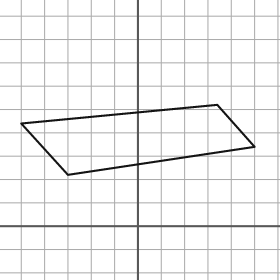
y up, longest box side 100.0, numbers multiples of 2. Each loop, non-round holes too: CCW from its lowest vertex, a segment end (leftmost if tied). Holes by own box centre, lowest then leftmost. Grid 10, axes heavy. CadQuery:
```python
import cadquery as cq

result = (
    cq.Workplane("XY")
    .moveTo(-30.0, 22.0)
    .lineTo(50.0, 34.0)
    .lineTo(34.0, 52.0)
    .lineTo(-50.0, 44.0)
    .close()
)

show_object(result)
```